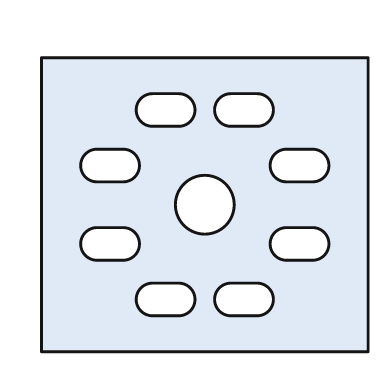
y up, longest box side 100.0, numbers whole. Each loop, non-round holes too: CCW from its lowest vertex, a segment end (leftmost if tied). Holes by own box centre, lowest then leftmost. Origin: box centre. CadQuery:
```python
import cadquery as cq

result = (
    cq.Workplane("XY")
    .moveTo(-50.0, -45.0)
    .lineTo(50.0, -45.0)
    .lineTo(50.0, 45.0)
    .lineTo(-50.0, 45.0)
    .close()
    .moveTo(-16.0, -34.0)
    .lineTo(-8.0, -34.0)
    .threePointArc((-3.0, -29.0), (-8.0, -24.0))
    .lineTo(-16.0, -24.0)
    .threePointArc((-21.0, -29.0), (-16.0, -34.0))
    .close()
    .moveTo(8.0, -34.0)
    .lineTo(16.0, -34.0)
    .threePointArc((21.0, -29.0), (16.0, -24.0))
    .lineTo(8.0, -24.0)
    .threePointArc((3.0, -29.0), (8.0, -34.0))
    .close()
    .moveTo(-33.0, -17.0)
    .lineTo(-25.0, -17.0)
    .threePointArc((-20.0, -12.0), (-25.0, -7.0))
    .lineTo(-33.0, -7.0)
    .threePointArc((-38.0, -12.0), (-33.0, -17.0))
    .close()
    .moveTo(25.0, -17.0)
    .lineTo(33.0, -17.0)
    .threePointArc((38.0, -12.0), (33.0, -7.0))
    .lineTo(25.0, -7.0)
    .threePointArc((20.0, -12.0), (25.0, -17.0))
    .close()
    .moveTo(0.0, 0.0)
    .circle(9.0)
    .moveTo(-33.0, 7.0)
    .lineTo(-25.0, 7.0)
    .threePointArc((-20.0, 12.0), (-25.0, 17.0))
    .lineTo(-33.0, 17.0)
    .threePointArc((-38.0, 12.0), (-33.0, 7.0))
    .close()
    .moveTo(25.0, 7.0)
    .lineTo(33.0, 7.0)
    .threePointArc((38.0, 12.0), (33.0, 17.0))
    .lineTo(25.0, 17.0)
    .threePointArc((20.0, 12.0), (25.0, 7.0))
    .close()
    .moveTo(-16.0, 24.0)
    .lineTo(-8.0, 24.0)
    .threePointArc((-3.0, 29.0), (-8.0, 34.0))
    .lineTo(-16.0, 34.0)
    .threePointArc((-21.0, 29.0), (-16.0, 24.0))
    .close()
    .moveTo(8.0, 24.0)
    .lineTo(16.0, 24.0)
    .threePointArc((21.0, 29.0), (16.0, 34.0))
    .lineTo(8.0, 34.0)
    .threePointArc((3.0, 29.0), (8.0, 24.0))
    .close()
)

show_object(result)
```